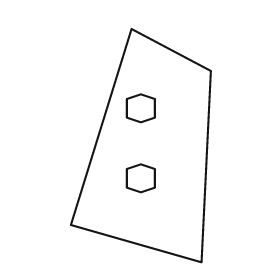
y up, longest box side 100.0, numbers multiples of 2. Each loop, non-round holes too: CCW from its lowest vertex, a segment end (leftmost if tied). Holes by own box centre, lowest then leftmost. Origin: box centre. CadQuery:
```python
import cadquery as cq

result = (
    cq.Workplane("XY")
    .moveTo(26.0, -50.0)
    .lineTo(30.0, 32.0)
    .lineTo(-4.0, 50.0)
    .lineTo(-30.0, -34.0)
    .close()
    .moveTo(0.0, -20.0)
    .lineTo(6.0, -18.0)
    .lineTo(6.0, -10.0)
    .lineTo(0.0, -8.0)
    .lineTo(-6.0, -10.0)
    .lineTo(-6.0, -18.0)
    .close()
    .moveTo(0.0, 10.0)
    .lineTo(6.0, 12.0)
    .lineTo(6.0, 20.0)
    .lineTo(0.0, 22.0)
    .lineTo(-6.0, 20.0)
    .lineTo(-6.0, 12.0)
    .close()
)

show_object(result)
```